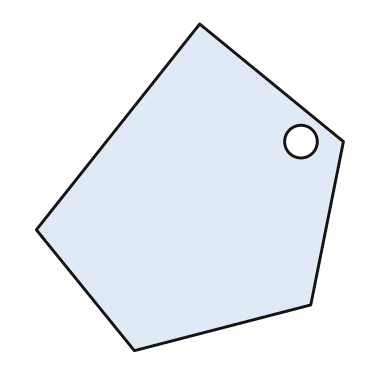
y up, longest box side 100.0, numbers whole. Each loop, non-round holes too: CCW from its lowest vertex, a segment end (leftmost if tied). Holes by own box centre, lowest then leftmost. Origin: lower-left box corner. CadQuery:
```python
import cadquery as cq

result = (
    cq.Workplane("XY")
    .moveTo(30.0, 0.0)
    .lineTo(84.0, 14.0)
    .lineTo(94.0, 64.0)
    .lineTo(50.0, 100.0)
    .lineTo(0.0, 37.0)
    .close()
    .moveTo(81.0, 64.0)
    .circle(5.0)
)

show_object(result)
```